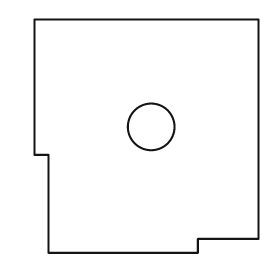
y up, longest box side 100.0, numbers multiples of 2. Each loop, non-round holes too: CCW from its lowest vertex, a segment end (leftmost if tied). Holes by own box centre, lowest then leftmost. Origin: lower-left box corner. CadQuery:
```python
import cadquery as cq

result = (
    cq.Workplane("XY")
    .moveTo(6.0, 0.0)
    .lineTo(70.0, 0.0)
    .lineTo(70.0, 6.0)
    .lineTo(96.0, 6.0)
    .lineTo(96.0, 100.0)
    .lineTo(0.0, 100.0)
    .lineTo(0.0, 42.0)
    .lineTo(6.0, 42.0)
    .close()
    .moveTo(50.0, 54.0)
    .circle(10.0)
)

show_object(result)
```